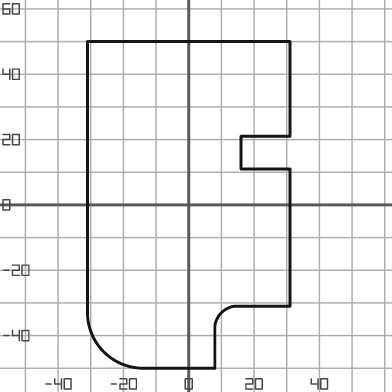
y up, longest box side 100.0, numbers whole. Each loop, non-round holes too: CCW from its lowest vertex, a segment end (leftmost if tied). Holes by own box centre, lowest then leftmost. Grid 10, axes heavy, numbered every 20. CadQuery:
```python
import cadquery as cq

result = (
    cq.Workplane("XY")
    .moveTo(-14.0, -50.0)
    .lineTo(8.0, -50.0)
    .lineTo(8.0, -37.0)
    .threePointArc((10.0, -33.0), (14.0, -31.0))
    .lineTo(31.0, -31.0)
    .lineTo(31.0, 11.0)
    .lineTo(16.0, 11.0)
    .lineTo(16.0, 21.0)
    .lineTo(31.0, 21.0)
    .lineTo(31.0, 50.0)
    .lineTo(-31.0, 50.0)
    .lineTo(-31.0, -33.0)
    .threePointArc((-26.0, -45.0), (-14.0, -50.0))
    .close()
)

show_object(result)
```